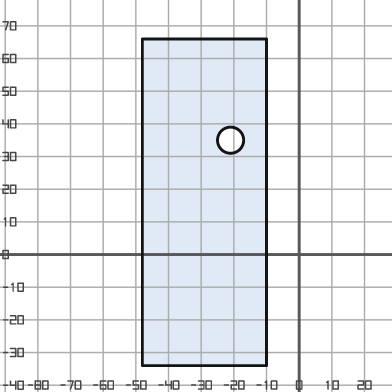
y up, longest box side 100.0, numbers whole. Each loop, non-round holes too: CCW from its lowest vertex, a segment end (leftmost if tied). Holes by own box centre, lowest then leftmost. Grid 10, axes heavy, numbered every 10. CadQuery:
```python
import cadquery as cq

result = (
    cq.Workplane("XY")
    .moveTo(-48.0, -34.0)
    .lineTo(-10.0, -34.0)
    .lineTo(-10.0, 66.0)
    .lineTo(-48.0, 66.0)
    .close()
    .moveTo(-21.0, 35.0)
    .circle(4.0)
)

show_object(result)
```